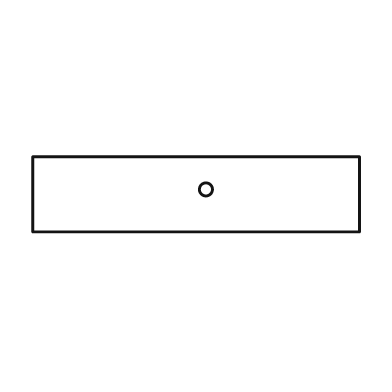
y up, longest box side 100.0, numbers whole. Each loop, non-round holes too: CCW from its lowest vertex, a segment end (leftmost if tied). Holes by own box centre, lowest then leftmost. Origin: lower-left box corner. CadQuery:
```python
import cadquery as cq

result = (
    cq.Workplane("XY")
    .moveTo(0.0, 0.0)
    .lineTo(100.0, 0.0)
    .lineTo(100.0, 23.0)
    .lineTo(0.0, 23.0)
    .close()
    .moveTo(53.0, 13.0)
    .circle(2.0)
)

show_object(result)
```